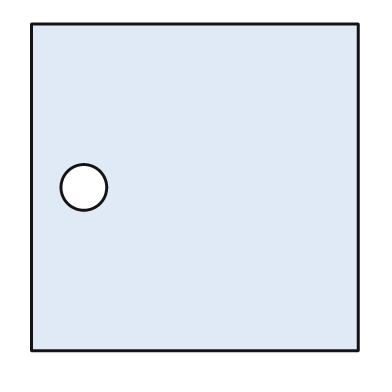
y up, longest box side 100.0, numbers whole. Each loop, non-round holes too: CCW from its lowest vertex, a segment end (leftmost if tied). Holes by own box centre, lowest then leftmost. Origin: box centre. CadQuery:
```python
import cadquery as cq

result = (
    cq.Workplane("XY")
    .moveTo(-50.0, -50.0)
    .lineTo(50.0, -50.0)
    .lineTo(50.0, 50.0)
    .lineTo(-50.0, 50.0)
    .close()
    .moveTo(-34.0, 0.0)
    .circle(7.0)
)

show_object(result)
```